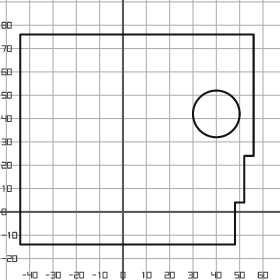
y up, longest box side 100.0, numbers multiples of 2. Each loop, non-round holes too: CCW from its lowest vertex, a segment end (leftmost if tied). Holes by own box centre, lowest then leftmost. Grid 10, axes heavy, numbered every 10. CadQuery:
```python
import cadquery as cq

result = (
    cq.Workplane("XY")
    .moveTo(-44.0, -14.0)
    .lineTo(48.0, -14.0)
    .lineTo(48.0, 4.0)
    .lineTo(52.0, 4.0)
    .lineTo(52.0, 24.0)
    .lineTo(56.0, 24.0)
    .lineTo(56.0, 76.0)
    .lineTo(-44.0, 76.0)
    .close()
    .moveTo(40.0, 42.0)
    .circle(10.0)
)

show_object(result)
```